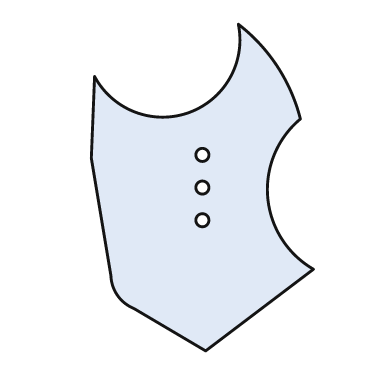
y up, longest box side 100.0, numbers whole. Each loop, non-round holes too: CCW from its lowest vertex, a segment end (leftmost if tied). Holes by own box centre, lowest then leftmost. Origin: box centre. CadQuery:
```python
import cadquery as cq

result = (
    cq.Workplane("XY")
    .moveTo(1.0, -50.0)
    .lineTo(34.0, -25.0)
    .threePointArc((20.0, -3.0), (30.0, 21.0))
    .threePointArc((23.0, 37.0), (11.0, 50.0))
    .threePointArc((-4.0, 23.0), (-33.0, 34.0))
    .lineTo(-34.0, 9.0)
    .lineTo(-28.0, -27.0)
    .threePointArc((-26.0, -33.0), (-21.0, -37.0))
    .close()
    .moveTo(0.0, -10.0)
    .circle(2.0)
    .moveTo(0.0, 0.0)
    .circle(2.0)
    .moveTo(0.0, 10.0)
    .circle(2.0)
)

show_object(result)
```